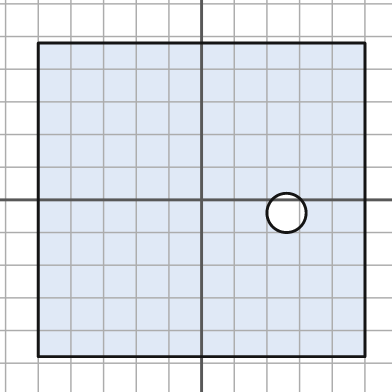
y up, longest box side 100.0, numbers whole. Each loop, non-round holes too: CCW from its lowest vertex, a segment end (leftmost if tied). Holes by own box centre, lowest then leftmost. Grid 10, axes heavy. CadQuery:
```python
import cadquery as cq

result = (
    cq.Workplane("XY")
    .moveTo(-50.0, -48.0)
    .lineTo(50.0, -48.0)
    .lineTo(50.0, 48.0)
    .lineTo(-50.0, 48.0)
    .close()
    .moveTo(26.0, -4.0)
    .circle(6.0)
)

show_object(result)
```